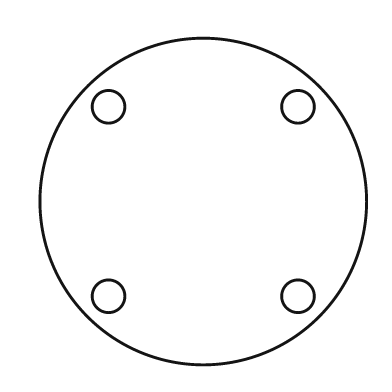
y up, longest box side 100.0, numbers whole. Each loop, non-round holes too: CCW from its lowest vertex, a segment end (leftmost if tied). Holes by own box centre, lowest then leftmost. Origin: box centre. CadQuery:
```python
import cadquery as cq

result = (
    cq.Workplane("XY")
    .moveTo(0.0, 0.0)
    .circle(50.0)
    .moveTo(-29.0, -29.0)
    .circle(5.0)
    .moveTo(29.0, -29.0)
    .circle(5.0)
    .moveTo(-29.0, 29.0)
    .circle(5.0)
    .moveTo(29.0, 29.0)
    .circle(5.0)
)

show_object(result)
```